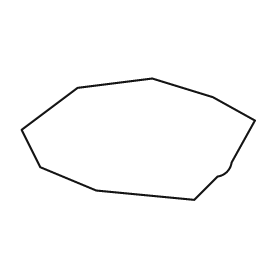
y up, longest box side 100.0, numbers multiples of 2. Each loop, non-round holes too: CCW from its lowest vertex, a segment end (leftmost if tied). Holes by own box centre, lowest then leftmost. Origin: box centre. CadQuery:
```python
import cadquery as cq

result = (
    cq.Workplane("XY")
    .moveTo(24.0, -26.0)
    .lineTo(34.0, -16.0)
    .threePointArc((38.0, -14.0), (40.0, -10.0))
    .lineTo(50.0, 8.0)
    .lineTo(32.0, 18.0)
    .lineTo(6.0, 26.0)
    .lineTo(-26.0, 22.0)
    .lineTo(-50.0, 4.0)
    .lineTo(-42.0, -12.0)
    .lineTo(-18.0, -22.0)
    .close()
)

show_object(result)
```